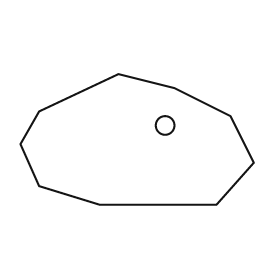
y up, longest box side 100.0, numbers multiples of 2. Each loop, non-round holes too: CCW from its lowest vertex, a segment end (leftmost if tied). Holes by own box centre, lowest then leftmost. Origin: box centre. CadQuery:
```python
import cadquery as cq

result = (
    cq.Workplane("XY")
    .moveTo(-16.0, -28.0)
    .lineTo(34.0, -28.0)
    .lineTo(50.0, -10.0)
    .lineTo(40.0, 10.0)
    .lineTo(16.0, 22.0)
    .lineTo(-8.0, 28.0)
    .lineTo(-42.0, 12.0)
    .lineTo(-50.0, -2.0)
    .lineTo(-42.0, -20.0)
    .close()
    .moveTo(12.0, 6.0)
    .circle(4.0)
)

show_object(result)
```